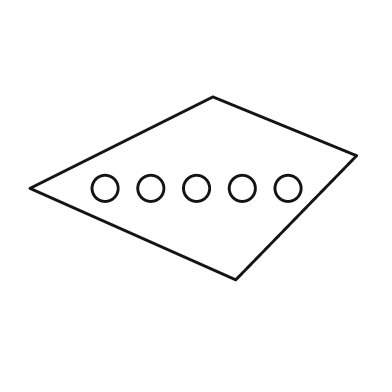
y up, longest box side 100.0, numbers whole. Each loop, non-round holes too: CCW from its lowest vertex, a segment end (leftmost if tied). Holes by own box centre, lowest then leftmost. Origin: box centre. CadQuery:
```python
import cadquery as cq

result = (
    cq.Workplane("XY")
    .moveTo(13.0, -28.0)
    .lineTo(50.0, 10.0)
    .lineTo(6.0, 28.0)
    .lineTo(-50.0, 0.0)
    .close()
    .moveTo(-27.0, 0.0)
    .circle(4.0)
    .moveTo(-13.0, 0.0)
    .circle(4.0)
    .moveTo(1.0, 0.0)
    .circle(4.0)
    .moveTo(15.0, 0.0)
    .circle(4.0)
    .moveTo(29.0, 0.0)
    .circle(4.0)
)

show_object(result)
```